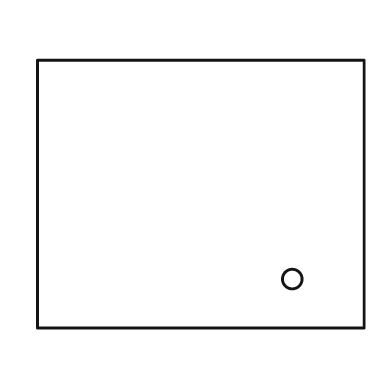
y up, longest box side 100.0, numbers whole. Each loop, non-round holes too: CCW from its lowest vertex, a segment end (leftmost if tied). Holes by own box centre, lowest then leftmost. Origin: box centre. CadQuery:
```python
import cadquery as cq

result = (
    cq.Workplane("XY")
    .moveTo(-50.0, -41.0)
    .lineTo(50.0, -41.0)
    .lineTo(50.0, 41.0)
    .lineTo(-50.0, 41.0)
    .close()
    .moveTo(28.0, -26.0)
    .circle(3.0)
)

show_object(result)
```